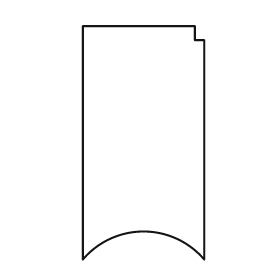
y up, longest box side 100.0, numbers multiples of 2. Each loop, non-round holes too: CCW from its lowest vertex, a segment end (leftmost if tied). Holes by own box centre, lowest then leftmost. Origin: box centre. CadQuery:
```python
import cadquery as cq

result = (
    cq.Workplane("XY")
    .moveTo(-26.0, -50.0)
    .threePointArc((0.0, -38.0), (26.0, -50.0))
    .lineTo(26.0, 44.0)
    .lineTo(22.0, 44.0)
    .lineTo(22.0, 50.0)
    .lineTo(-26.0, 50.0)
    .close()
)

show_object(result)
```